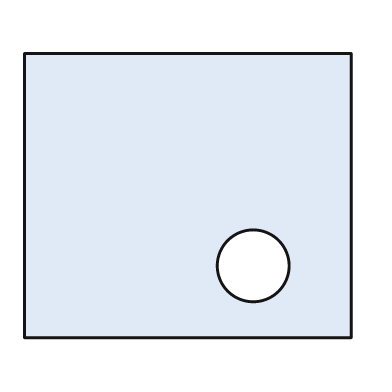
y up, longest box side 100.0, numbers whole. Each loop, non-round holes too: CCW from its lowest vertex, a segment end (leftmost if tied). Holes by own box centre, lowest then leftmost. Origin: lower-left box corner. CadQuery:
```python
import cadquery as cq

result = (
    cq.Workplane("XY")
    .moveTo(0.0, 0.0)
    .lineTo(100.0, 0.0)
    .lineTo(100.0, 87.0)
    .lineTo(0.0, 87.0)
    .close()
    .moveTo(70.0, 22.0)
    .circle(11.0)
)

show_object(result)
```